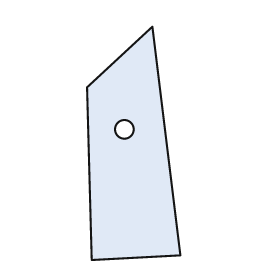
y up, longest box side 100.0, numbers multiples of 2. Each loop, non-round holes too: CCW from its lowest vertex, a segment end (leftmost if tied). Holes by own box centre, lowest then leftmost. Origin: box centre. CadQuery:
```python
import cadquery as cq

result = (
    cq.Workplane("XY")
    .moveTo(-18.0, -50.0)
    .lineTo(20.0, -48.0)
    .lineTo(8.0, 50.0)
    .lineTo(-20.0, 24.0)
    .close()
    .moveTo(-4.0, 6.0)
    .circle(4.0)
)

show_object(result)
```